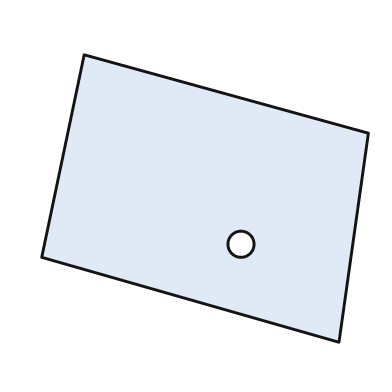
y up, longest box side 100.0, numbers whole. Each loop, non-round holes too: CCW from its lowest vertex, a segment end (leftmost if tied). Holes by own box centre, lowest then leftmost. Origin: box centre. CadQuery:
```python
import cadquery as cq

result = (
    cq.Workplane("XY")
    .moveTo(41.0, -44.0)
    .lineTo(50.0, 20.0)
    .lineTo(-37.0, 44.0)
    .lineTo(-50.0, -18.0)
    .close()
    .moveTo(11.0, -14.0)
    .circle(4.0)
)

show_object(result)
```